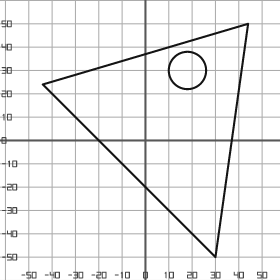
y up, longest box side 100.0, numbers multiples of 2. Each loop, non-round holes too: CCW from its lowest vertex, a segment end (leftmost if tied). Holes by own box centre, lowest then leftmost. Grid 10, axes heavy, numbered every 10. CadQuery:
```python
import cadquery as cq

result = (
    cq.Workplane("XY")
    .moveTo(30.0, -50.0)
    .lineTo(44.0, 50.0)
    .lineTo(-44.0, 24.0)
    .close()
    .moveTo(18.0, 30.0)
    .circle(8.0)
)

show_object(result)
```